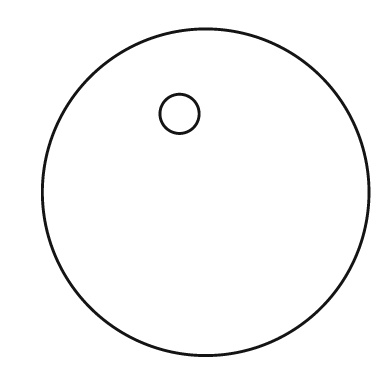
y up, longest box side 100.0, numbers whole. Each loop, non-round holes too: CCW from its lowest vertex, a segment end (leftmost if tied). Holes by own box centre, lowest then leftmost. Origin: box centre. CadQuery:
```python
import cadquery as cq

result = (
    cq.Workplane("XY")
    .moveTo(0.0, 0.0)
    .circle(50.0)
    .moveTo(-8.0, 24.0)
    .circle(6.0)
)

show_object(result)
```